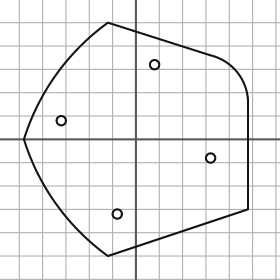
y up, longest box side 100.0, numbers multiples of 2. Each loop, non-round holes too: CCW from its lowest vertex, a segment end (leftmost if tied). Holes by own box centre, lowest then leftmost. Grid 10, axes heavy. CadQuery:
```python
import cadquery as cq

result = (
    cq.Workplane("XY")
    .moveTo(-12.0, -50.0)
    .lineTo(48.0, -30.0)
    .lineTo(48.0, 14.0)
    .threePointArc((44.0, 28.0), (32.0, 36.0))
    .lineTo(-12.0, 50.0)
    .threePointArc((-34.0, 28.0), (-48.0, 0.0))
    .threePointArc((-34.0, -28.0), (-12.0, -50.0))
    .close()
    .moveTo(-8.0, -32.0)
    .circle(2.0)
    .moveTo(32.0, -8.0)
    .circle(2.0)
    .moveTo(-32.0, 8.0)
    .circle(2.0)
    .moveTo(8.0, 32.0)
    .circle(2.0)
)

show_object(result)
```